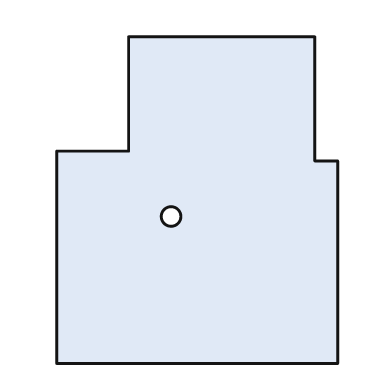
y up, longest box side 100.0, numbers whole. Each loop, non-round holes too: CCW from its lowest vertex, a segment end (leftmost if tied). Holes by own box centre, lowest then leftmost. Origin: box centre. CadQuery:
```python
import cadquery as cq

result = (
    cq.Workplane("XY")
    .moveTo(-43.0, -50.0)
    .lineTo(43.0, -50.0)
    .lineTo(43.0, 12.0)
    .lineTo(36.0, 12.0)
    .lineTo(36.0, 50.0)
    .lineTo(-21.0, 50.0)
    .lineTo(-21.0, 15.0)
    .lineTo(-43.0, 15.0)
    .close()
    .moveTo(-8.0, -5.0)
    .circle(3.0)
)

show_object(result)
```